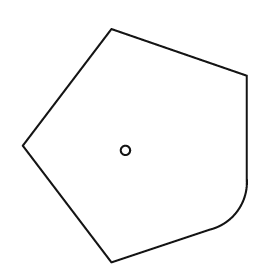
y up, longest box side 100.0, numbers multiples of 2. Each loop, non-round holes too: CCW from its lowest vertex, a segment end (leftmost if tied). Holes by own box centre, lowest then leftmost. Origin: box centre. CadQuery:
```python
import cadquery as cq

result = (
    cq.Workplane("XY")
    .moveTo(-10.0, -50.0)
    .lineTo(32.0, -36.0)
    .threePointArc((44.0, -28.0), (48.0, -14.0))
    .lineTo(48.0, 30.0)
    .lineTo(-10.0, 50.0)
    .lineTo(-48.0, 0.0)
    .close()
    .moveTo(-4.0, -2.0)
    .circle(2.0)
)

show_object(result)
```